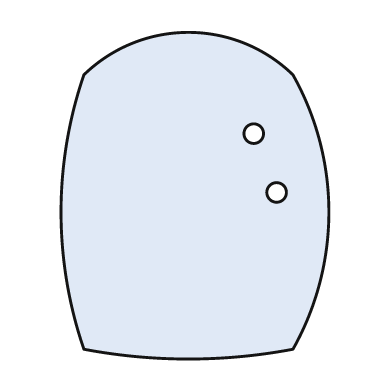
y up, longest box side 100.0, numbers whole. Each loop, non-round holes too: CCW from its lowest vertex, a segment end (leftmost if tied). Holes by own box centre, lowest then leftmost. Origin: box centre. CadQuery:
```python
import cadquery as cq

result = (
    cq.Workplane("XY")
    .moveTo(-34.0, -47.0)
    .threePointArc((-2.0, -50.0), (30.0, -47.0))
    .threePointArc((41.0, -5.0), (30.0, 37.0))
    .threePointArc((-2.0, 50.0), (-34.0, 37.0))
    .threePointArc((-41.0, -5.0), (-34.0, -47.0))
    .close()
    .moveTo(25.0, 1.0)
    .circle(3.0)
    .moveTo(18.0, 19.0)
    .circle(3.0)
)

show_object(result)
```